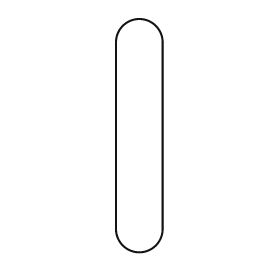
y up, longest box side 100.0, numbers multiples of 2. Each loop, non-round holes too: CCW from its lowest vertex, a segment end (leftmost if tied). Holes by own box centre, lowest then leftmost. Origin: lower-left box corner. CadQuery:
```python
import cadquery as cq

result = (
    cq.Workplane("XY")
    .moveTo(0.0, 10.0)
    .threePointArc((10.0, 0.0), (20.0, 10.0))
    .lineTo(20.0, 90.0)
    .threePointArc((10.0, 100.0), (0.0, 90.0))
    .close()
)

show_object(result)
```